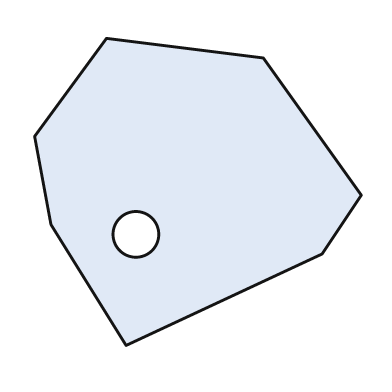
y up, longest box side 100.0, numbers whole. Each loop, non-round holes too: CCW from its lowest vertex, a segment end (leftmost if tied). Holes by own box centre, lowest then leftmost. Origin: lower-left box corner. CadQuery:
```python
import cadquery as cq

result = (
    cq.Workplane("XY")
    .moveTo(28.0, 0.0)
    .lineTo(88.0, 28.0)
    .lineTo(100.0, 46.0)
    .lineTo(70.0, 88.0)
    .lineTo(22.0, 94.0)
    .lineTo(0.0, 64.0)
    .lineTo(5.0, 37.0)
    .close()
    .moveTo(31.0, 34.0)
    .circle(7.0)
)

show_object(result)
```